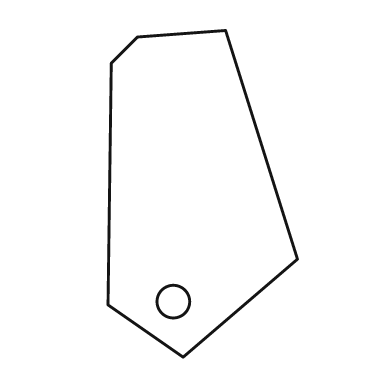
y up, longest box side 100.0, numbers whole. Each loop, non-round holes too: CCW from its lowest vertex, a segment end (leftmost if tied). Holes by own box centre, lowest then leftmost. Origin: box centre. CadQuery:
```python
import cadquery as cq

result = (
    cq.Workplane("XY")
    .moveTo(-6.0, -50.0)
    .lineTo(29.0, -20.0)
    .lineTo(7.0, 50.0)
    .lineTo(-20.0, 48.0)
    .lineTo(-28.0, 40.0)
    .lineTo(-29.0, -34.0)
    .close()
    .moveTo(-9.0, -33.0)
    .circle(5.0)
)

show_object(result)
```